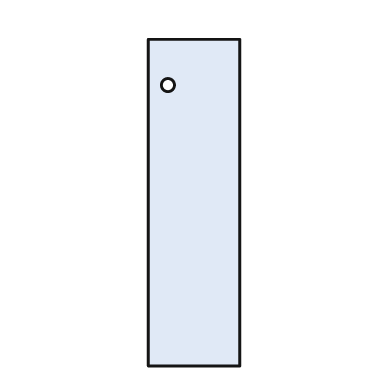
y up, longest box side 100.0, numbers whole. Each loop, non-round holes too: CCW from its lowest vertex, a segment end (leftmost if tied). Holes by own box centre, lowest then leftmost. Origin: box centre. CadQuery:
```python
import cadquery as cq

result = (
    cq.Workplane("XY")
    .moveTo(-14.0, -50.0)
    .lineTo(14.0, -50.0)
    .lineTo(14.0, 50.0)
    .lineTo(-14.0, 50.0)
    .close()
    .moveTo(-8.0, 36.0)
    .circle(2.0)
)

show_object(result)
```